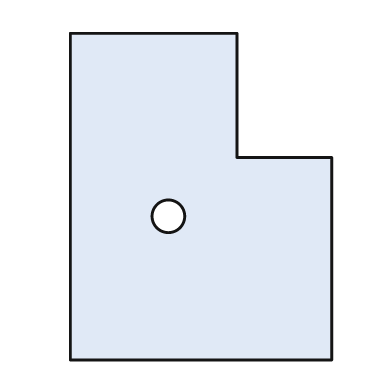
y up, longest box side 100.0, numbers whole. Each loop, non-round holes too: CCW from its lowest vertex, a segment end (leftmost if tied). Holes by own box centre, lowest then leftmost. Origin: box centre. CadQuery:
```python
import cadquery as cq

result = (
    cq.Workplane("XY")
    .moveTo(-40.0, -50.0)
    .lineTo(40.0, -50.0)
    .lineTo(40.0, 12.0)
    .lineTo(11.0, 12.0)
    .lineTo(11.0, 50.0)
    .lineTo(-40.0, 50.0)
    .close()
    .moveTo(-10.0, -6.0)
    .circle(5.0)
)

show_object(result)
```